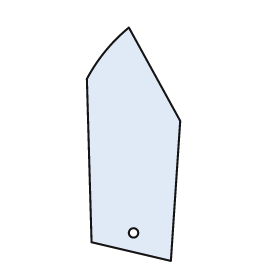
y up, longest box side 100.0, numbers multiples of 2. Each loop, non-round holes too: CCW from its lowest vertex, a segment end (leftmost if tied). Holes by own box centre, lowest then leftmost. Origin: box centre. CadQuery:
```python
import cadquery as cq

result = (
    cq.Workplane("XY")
    .moveTo(16.0, -50.0)
    .lineTo(20.0, 10.0)
    .lineTo(-2.0, 50.0)
    .threePointArc((-12.0, 40.0), (-20.0, 28.0))
    .lineTo(-18.0, -42.0)
    .close()
    .moveTo(0.0, -38.0)
    .circle(2.0)
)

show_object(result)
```